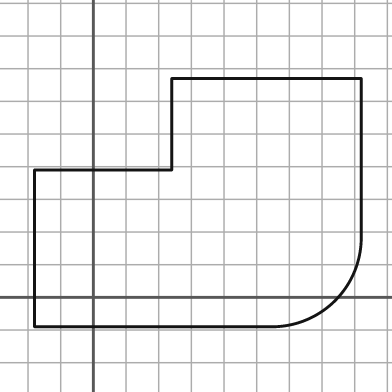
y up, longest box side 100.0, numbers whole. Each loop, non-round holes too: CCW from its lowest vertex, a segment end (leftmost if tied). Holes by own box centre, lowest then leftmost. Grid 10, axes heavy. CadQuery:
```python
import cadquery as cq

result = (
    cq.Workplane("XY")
    .moveTo(-18.0, -9.0)
    .lineTo(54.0, -9.0)
    .threePointArc((74.0, -1.0), (82.0, 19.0))
    .lineTo(82.0, 67.0)
    .lineTo(24.0, 67.0)
    .lineTo(24.0, 39.0)
    .lineTo(-18.0, 39.0)
    .close()
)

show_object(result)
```